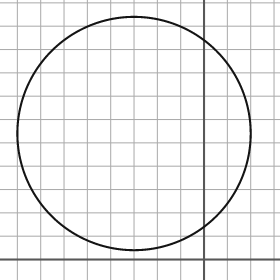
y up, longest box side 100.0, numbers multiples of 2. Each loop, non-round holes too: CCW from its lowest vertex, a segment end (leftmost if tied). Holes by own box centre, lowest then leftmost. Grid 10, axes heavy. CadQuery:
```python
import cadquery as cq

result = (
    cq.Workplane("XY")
    .moveTo(-30.0, 54.0)
    .circle(50.0)
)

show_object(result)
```